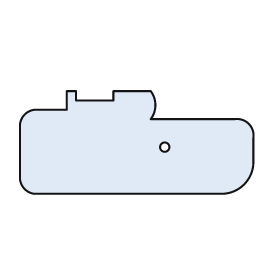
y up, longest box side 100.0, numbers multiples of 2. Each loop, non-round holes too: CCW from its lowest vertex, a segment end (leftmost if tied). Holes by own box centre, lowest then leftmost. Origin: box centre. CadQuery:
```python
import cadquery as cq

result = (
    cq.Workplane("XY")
    .moveTo(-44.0, -22.0)
    .lineTo(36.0, -22.0)
    .threePointArc((46.0, -18.0), (50.0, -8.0))
    .lineTo(50.0, 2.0)
    .threePointArc((48.0, 8.0), (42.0, 10.0))
    .lineTo(6.0, 10.0)
    .threePointArc((8.0, 16.0), (6.0, 22.0))
    .lineTo(-10.0, 22.0)
    .lineTo(-10.0, 18.0)
    .lineTo(-26.0, 18.0)
    .lineTo(-26.0, 22.0)
    .lineTo(-30.0, 22.0)
    .lineTo(-30.0, 14.0)
    .lineTo(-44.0, 14.0)
    .threePointArc((-48.0, 12.0), (-50.0, 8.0))
    .lineTo(-50.0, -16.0)
    .threePointArc((-48.0, -20.0), (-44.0, -22.0))
    .close()
    .moveTo(12.0, -2.0)
    .circle(2.0)
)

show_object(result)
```